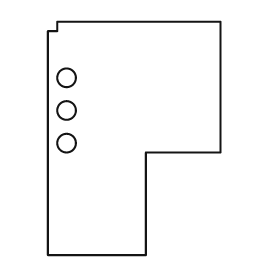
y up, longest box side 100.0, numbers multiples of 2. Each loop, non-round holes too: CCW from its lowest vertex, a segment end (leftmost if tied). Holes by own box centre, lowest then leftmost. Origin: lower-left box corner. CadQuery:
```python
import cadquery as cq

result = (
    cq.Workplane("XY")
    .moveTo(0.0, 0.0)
    .lineTo(42.0, 0.0)
    .lineTo(42.0, 44.0)
    .lineTo(74.0, 44.0)
    .lineTo(74.0, 100.0)
    .lineTo(4.0, 100.0)
    .lineTo(4.0, 96.0)
    .lineTo(0.0, 96.0)
    .close()
    .moveTo(8.0, 48.0)
    .circle(4.0)
    .moveTo(8.0, 62.0)
    .circle(4.0)
    .moveTo(8.0, 76.0)
    .circle(4.0)
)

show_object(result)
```